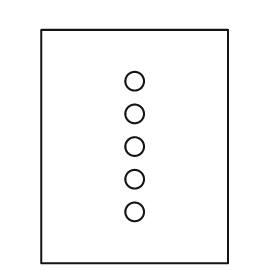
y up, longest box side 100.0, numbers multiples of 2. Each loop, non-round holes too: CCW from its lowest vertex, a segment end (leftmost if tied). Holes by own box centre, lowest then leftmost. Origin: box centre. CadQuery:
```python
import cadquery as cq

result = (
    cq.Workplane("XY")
    .moveTo(-40.0, -50.0)
    .lineTo(40.0, -50.0)
    .lineTo(40.0, 50.0)
    .lineTo(-40.0, 50.0)
    .close()
    .moveTo(0.0, -28.0)
    .circle(4.0)
    .moveTo(0.0, -14.0)
    .circle(4.0)
    .moveTo(0.0, 0.0)
    .circle(4.0)
    .moveTo(0.0, 14.0)
    .circle(4.0)
    .moveTo(0.0, 28.0)
    .circle(4.0)
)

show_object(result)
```